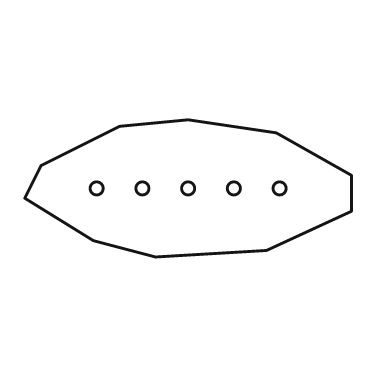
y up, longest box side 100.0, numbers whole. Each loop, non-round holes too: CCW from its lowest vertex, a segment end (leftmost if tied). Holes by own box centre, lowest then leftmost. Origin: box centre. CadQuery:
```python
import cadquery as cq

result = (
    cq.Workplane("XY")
    .moveTo(-10.0, -21.0)
    .lineTo(24.0, -19.0)
    .lineTo(50.0, -7.0)
    .lineTo(50.0, 4.0)
    .lineTo(27.0, 17.0)
    .lineTo(0.0, 21.0)
    .lineTo(-21.0, 19.0)
    .lineTo(-45.0, 7.0)
    .lineTo(-50.0, -3.0)
    .lineTo(-29.0, -16.0)
    .close()
    .moveTo(-28.0, 0.0)
    .circle(2.0)
    .moveTo(-14.0, 0.0)
    .circle(2.0)
    .moveTo(0.0, 0.0)
    .circle(2.0)
    .moveTo(14.0, 0.0)
    .circle(2.0)
    .moveTo(28.0, 0.0)
    .circle(2.0)
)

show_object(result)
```